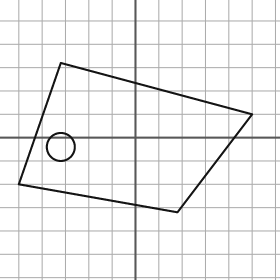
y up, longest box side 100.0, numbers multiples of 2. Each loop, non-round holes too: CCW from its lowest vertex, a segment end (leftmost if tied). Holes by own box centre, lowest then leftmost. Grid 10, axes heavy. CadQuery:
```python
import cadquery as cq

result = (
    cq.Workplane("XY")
    .moveTo(18.0, -32.0)
    .lineTo(50.0, 10.0)
    .lineTo(-32.0, 32.0)
    .lineTo(-50.0, -20.0)
    .close()
    .moveTo(-32.0, -4.0)
    .circle(6.0)
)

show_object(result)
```